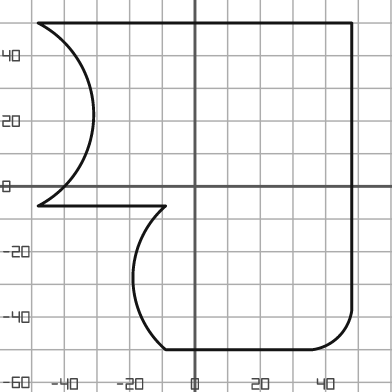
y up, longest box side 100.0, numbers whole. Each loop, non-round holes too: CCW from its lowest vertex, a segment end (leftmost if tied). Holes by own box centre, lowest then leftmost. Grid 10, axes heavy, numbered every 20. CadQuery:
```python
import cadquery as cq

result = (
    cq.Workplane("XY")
    .moveTo(-9.0, -50.0)
    .lineTo(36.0, -50.0)
    .threePointArc((44.0, -46.0), (48.0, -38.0))
    .lineTo(48.0, 50.0)
    .lineTo(-48.0, 50.0)
    .threePointArc((-31.0, 22.0), (-48.0, -6.0))
    .lineTo(-9.0, -6.0)
    .threePointArc((-19.0, -28.0), (-9.0, -50.0))
    .close()
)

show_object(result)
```